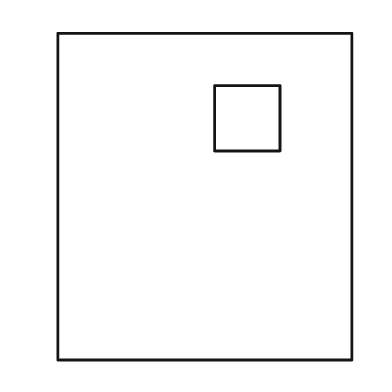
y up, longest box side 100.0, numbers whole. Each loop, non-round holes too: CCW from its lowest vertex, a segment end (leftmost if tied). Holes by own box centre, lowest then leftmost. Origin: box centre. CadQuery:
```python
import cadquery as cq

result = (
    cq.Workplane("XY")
    .moveTo(-45.0, -50.0)
    .lineTo(45.0, -50.0)
    .lineTo(45.0, 50.0)
    .lineTo(-45.0, 50.0)
    .close()
    .moveTo(3.0, 14.0)
    .lineTo(23.0, 14.0)
    .lineTo(23.0, 34.0)
    .lineTo(3.0, 34.0)
    .close()
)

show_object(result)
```